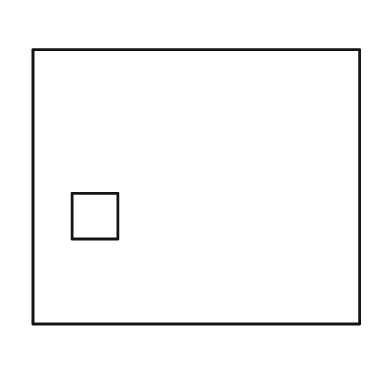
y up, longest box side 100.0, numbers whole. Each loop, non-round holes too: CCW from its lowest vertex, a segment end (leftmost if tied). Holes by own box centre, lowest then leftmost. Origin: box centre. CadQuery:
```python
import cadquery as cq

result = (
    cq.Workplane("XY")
    .moveTo(-50.0, -42.0)
    .lineTo(50.0, -42.0)
    .lineTo(50.0, 42.0)
    .lineTo(-50.0, 42.0)
    .close()
    .moveTo(-38.0, -16.0)
    .lineTo(-24.0, -16.0)
    .lineTo(-24.0, -2.0)
    .lineTo(-38.0, -2.0)
    .close()
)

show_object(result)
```